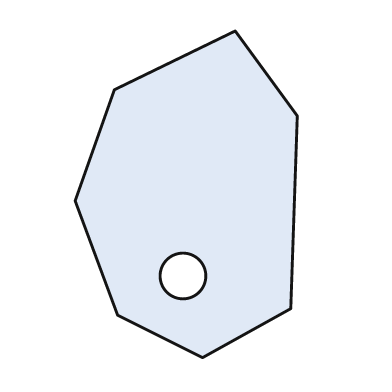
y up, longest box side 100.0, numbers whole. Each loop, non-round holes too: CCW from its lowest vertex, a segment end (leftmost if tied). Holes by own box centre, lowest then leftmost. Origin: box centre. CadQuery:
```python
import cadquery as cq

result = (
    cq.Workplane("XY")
    .moveTo(5.0, -50.0)
    .lineTo(32.0, -35.0)
    .lineTo(34.0, 24.0)
    .lineTo(15.0, 50.0)
    .lineTo(-22.0, 32.0)
    .lineTo(-34.0, -2.0)
    .lineTo(-21.0, -37.0)
    .close()
    .moveTo(-1.0, -25.0)
    .circle(7.0)
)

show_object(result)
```